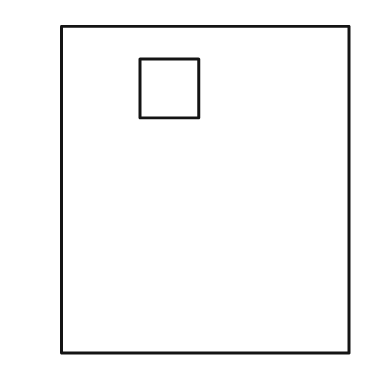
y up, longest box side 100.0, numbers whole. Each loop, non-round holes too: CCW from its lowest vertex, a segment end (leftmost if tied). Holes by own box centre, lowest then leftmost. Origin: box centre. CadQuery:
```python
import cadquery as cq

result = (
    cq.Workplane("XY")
    .moveTo(-44.0, -50.0)
    .lineTo(44.0, -50.0)
    .lineTo(44.0, 50.0)
    .lineTo(-44.0, 50.0)
    .close()
    .moveTo(-20.0, 22.0)
    .lineTo(-2.0, 22.0)
    .lineTo(-2.0, 40.0)
    .lineTo(-20.0, 40.0)
    .close()
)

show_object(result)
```